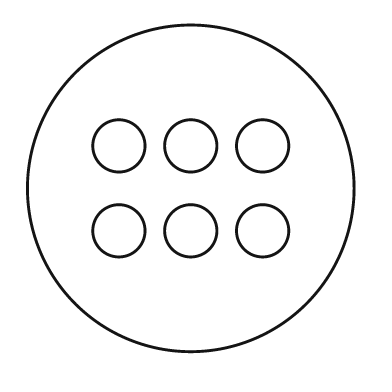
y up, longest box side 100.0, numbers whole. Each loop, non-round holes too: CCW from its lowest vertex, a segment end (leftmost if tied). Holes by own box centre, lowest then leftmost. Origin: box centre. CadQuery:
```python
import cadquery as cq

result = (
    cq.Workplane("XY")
    .moveTo(0.0, 0.0)
    .circle(50.0)
    .moveTo(-22.0, -13.0)
    .circle(8.0)
    .moveTo(0.0, -13.0)
    .circle(8.0)
    .moveTo(22.0, -13.0)
    .circle(8.0)
    .moveTo(-22.0, 13.0)
    .circle(8.0)
    .moveTo(0.0, 13.0)
    .circle(8.0)
    .moveTo(22.0, 13.0)
    .circle(8.0)
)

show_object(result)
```